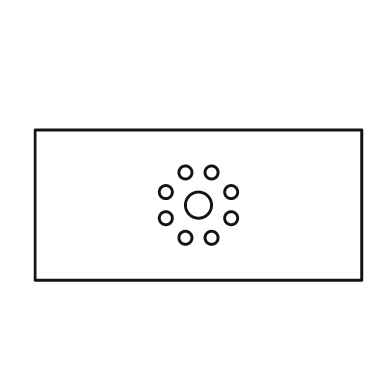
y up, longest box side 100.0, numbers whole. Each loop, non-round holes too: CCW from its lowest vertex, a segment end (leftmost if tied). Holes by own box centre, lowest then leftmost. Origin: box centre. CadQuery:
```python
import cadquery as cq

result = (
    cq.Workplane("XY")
    .moveTo(-50.0, -23.0)
    .lineTo(50.0, -23.0)
    .lineTo(50.0, 23.0)
    .lineTo(-50.0, 23.0)
    .close()
    .moveTo(-4.0, -10.0)
    .circle(2.0)
    .moveTo(4.0, -10.0)
    .circle(2.0)
    .moveTo(-10.0, -4.0)
    .circle(2.0)
    .moveTo(10.0, -4.0)
    .circle(2.0)
    .moveTo(0.0, 0.0)
    .circle(4.0)
    .moveTo(-10.0, 4.0)
    .circle(2.0)
    .moveTo(10.0, 4.0)
    .circle(2.0)
    .moveTo(-4.0, 10.0)
    .circle(2.0)
    .moveTo(4.0, 10.0)
    .circle(2.0)
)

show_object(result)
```